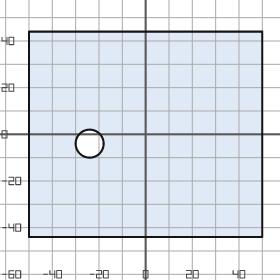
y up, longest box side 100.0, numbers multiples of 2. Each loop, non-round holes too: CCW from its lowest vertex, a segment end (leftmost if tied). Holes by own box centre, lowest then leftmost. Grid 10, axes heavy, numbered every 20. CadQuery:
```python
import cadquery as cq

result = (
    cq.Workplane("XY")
    .moveTo(-50.0, -44.0)
    .lineTo(50.0, -44.0)
    .lineTo(50.0, 44.0)
    .lineTo(-50.0, 44.0)
    .close()
    .moveTo(-24.0, -4.0)
    .circle(6.0)
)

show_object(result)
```